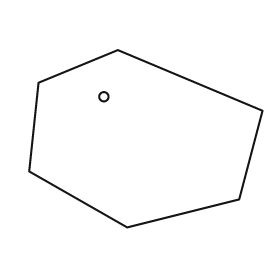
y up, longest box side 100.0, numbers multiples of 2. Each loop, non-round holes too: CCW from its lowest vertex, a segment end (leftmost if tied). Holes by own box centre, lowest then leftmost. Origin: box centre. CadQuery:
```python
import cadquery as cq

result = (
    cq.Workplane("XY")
    .moveTo(-8.0, -38.0)
    .lineTo(40.0, -26.0)
    .lineTo(50.0, 12.0)
    .lineTo(-12.0, 38.0)
    .lineTo(-46.0, 24.0)
    .lineTo(-50.0, -14.0)
    .close()
    .moveTo(-18.0, 18.0)
    .circle(2.0)
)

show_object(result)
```